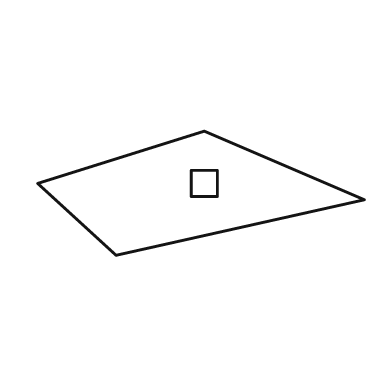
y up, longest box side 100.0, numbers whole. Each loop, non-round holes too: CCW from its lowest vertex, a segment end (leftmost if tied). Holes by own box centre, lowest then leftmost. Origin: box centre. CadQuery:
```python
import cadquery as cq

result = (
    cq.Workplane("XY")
    .moveTo(-26.0, -19.0)
    .lineTo(50.0, -2.0)
    .lineTo(1.0, 19.0)
    .lineTo(-50.0, 3.0)
    .close()
    .moveTo(-3.0, -1.0)
    .lineTo(5.0, -1.0)
    .lineTo(5.0, 7.0)
    .lineTo(-3.0, 7.0)
    .close()
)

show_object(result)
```